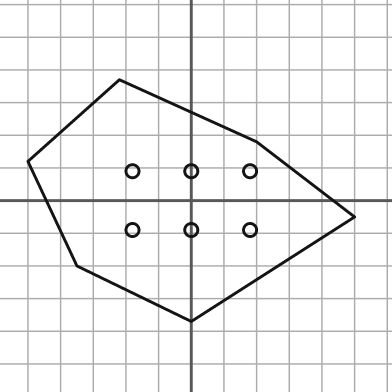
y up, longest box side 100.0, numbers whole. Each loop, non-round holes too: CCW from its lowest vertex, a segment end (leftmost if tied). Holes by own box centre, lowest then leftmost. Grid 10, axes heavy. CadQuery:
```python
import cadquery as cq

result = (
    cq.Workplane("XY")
    .moveTo(0.0, -37.0)
    .lineTo(50.0, -5.0)
    .lineTo(20.0, 18.0)
    .lineTo(-22.0, 37.0)
    .lineTo(-50.0, 12.0)
    .lineTo(-35.0, -20.0)
    .close()
    .moveTo(-18.0, -9.0)
    .circle(2.0)
    .moveTo(0.0, -9.0)
    .circle(2.0)
    .moveTo(18.0, -9.0)
    .circle(2.0)
    .moveTo(-18.0, 9.0)
    .circle(2.0)
    .moveTo(0.0, 9.0)
    .circle(2.0)
    .moveTo(18.0, 9.0)
    .circle(2.0)
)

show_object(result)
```